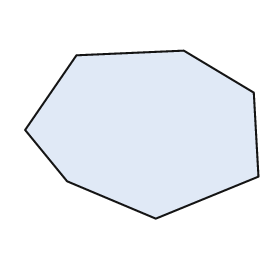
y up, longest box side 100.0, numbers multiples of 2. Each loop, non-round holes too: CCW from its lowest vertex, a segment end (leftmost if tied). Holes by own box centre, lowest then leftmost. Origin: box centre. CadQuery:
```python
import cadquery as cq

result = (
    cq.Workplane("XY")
    .moveTo(6.0, -36.0)
    .lineTo(50.0, -18.0)
    .lineTo(48.0, 18.0)
    .lineTo(18.0, 36.0)
    .lineTo(-28.0, 34.0)
    .lineTo(-50.0, 2.0)
    .lineTo(-32.0, -20.0)
    .close()
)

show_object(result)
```